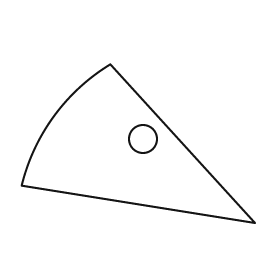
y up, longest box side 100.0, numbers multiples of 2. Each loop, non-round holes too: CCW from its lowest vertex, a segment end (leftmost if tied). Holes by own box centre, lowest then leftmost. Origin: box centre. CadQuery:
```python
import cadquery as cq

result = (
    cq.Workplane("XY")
    .moveTo(50.0, -34.0)
    .lineTo(-12.0, 34.0)
    .threePointArc((-36.0, 12.0), (-50.0, -18.0))
    .close()
    .moveTo(2.0, 2.0)
    .circle(6.0)
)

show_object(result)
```